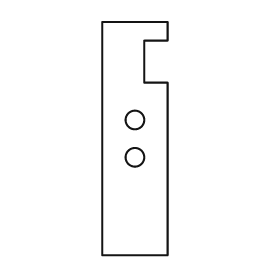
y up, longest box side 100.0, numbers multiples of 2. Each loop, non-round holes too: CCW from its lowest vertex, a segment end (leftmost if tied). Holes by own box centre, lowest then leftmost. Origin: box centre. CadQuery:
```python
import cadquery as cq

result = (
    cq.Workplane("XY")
    .moveTo(-14.0, -50.0)
    .lineTo(14.0, -50.0)
    .lineTo(14.0, 24.0)
    .lineTo(4.0, 24.0)
    .lineTo(4.0, 42.0)
    .lineTo(14.0, 42.0)
    .lineTo(14.0, 50.0)
    .lineTo(-14.0, 50.0)
    .close()
    .moveTo(0.0, -8.0)
    .circle(4.0)
    .moveTo(0.0, 8.0)
    .circle(4.0)
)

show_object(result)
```